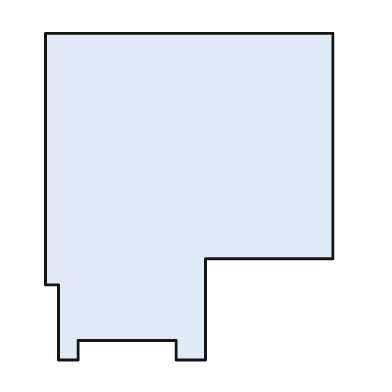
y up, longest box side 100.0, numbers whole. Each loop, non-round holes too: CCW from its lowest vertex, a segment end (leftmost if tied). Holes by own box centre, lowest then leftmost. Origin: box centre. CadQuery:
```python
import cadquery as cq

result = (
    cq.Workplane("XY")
    .moveTo(-40.0, -50.0)
    .lineTo(-34.0, -50.0)
    .lineTo(-34.0, -44.0)
    .lineTo(-4.0, -44.0)
    .lineTo(-4.0, -50.0)
    .lineTo(5.0, -50.0)
    .lineTo(5.0, -19.0)
    .lineTo(44.0, -19.0)
    .lineTo(44.0, 50.0)
    .lineTo(-44.0, 50.0)
    .lineTo(-44.0, -27.0)
    .lineTo(-40.0, -27.0)
    .close()
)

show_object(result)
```